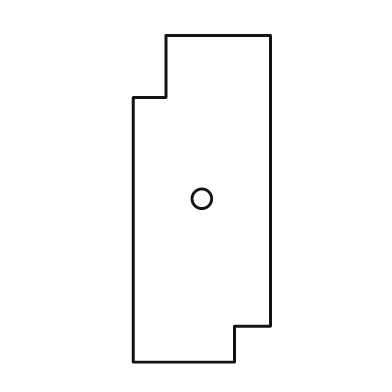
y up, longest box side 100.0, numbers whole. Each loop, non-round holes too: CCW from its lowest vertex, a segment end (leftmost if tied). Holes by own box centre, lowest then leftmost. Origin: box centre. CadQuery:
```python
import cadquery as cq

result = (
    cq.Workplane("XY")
    .moveTo(-21.0, -50.0)
    .lineTo(10.0, -50.0)
    .lineTo(10.0, -39.0)
    .lineTo(21.0, -39.0)
    .lineTo(21.0, 50.0)
    .lineTo(-11.0, 50.0)
    .lineTo(-11.0, 31.0)
    .lineTo(-21.0, 31.0)
    .close()
    .moveTo(0.0, 0.0)
    .circle(3.0)
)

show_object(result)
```